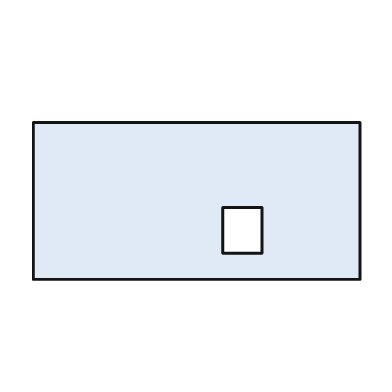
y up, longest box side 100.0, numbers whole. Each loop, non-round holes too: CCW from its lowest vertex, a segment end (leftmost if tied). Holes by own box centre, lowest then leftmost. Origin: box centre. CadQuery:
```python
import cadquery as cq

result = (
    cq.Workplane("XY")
    .moveTo(-50.0, -24.0)
    .lineTo(50.0, -24.0)
    .lineTo(50.0, 24.0)
    .lineTo(-50.0, 24.0)
    .close()
    .moveTo(8.0, -16.0)
    .lineTo(20.0, -16.0)
    .lineTo(20.0, -2.0)
    .lineTo(8.0, -2.0)
    .close()
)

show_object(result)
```